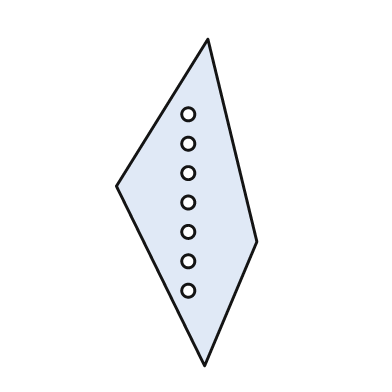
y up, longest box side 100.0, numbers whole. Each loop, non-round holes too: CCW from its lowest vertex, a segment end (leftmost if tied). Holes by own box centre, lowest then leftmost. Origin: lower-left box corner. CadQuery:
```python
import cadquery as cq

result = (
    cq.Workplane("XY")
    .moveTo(27.0, 0.0)
    .lineTo(43.0, 38.0)
    .lineTo(28.0, 100.0)
    .lineTo(0.0, 55.0)
    .close()
    .moveTo(22.0, 23.0)
    .circle(2.0)
    .moveTo(22.0, 32.0)
    .circle(2.0)
    .moveTo(22.0, 41.0)
    .circle(2.0)
    .moveTo(22.0, 50.0)
    .circle(2.0)
    .moveTo(22.0, 59.0)
    .circle(2.0)
    .moveTo(22.0, 68.0)
    .circle(2.0)
    .moveTo(22.0, 77.0)
    .circle(2.0)
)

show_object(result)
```